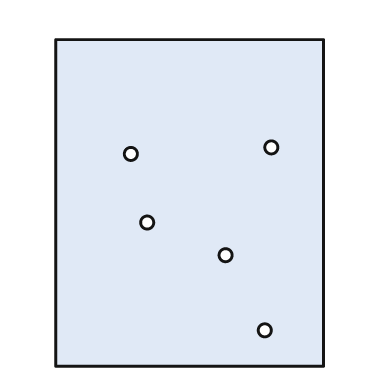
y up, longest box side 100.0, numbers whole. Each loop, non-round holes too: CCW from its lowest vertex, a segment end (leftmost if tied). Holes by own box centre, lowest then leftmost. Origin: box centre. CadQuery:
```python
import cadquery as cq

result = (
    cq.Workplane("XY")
    .moveTo(-41.0, -50.0)
    .lineTo(41.0, -50.0)
    .lineTo(41.0, 50.0)
    .lineTo(-41.0, 50.0)
    .close()
    .moveTo(23.0, -39.0)
    .circle(2.0)
    .moveTo(11.0, -16.0)
    .circle(2.0)
    .moveTo(-13.0, -6.0)
    .circle(2.0)
    .moveTo(-18.0, 15.0)
    .circle(2.0)
    .moveTo(25.0, 17.0)
    .circle(2.0)
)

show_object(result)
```